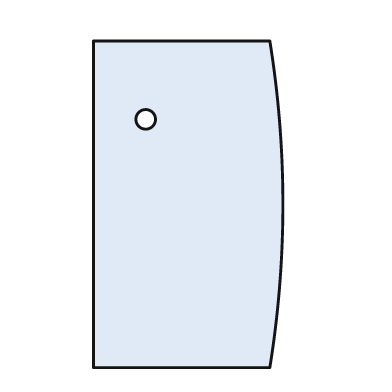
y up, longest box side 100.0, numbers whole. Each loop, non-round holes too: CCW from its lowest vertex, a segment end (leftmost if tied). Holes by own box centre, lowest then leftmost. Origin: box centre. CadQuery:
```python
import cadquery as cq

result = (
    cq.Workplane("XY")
    .moveTo(-29.0, -50.0)
    .lineTo(25.0, -50.0)
    .threePointArc((29.0, 0.0), (25.0, 50.0))
    .lineTo(-29.0, 50.0)
    .close()
    .moveTo(-13.0, 26.0)
    .circle(3.0)
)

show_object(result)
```